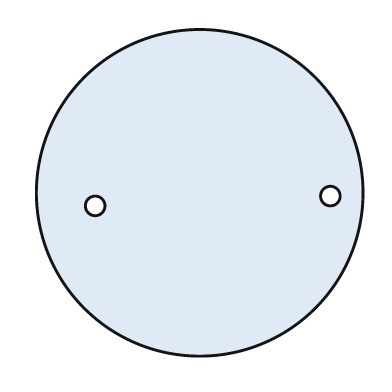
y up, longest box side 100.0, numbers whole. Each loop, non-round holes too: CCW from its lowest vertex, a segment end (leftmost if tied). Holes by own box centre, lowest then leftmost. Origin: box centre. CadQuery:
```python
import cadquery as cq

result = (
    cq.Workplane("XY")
    .moveTo(0.0, 0.0)
    .circle(50.0)
    .moveTo(-32.0, -4.0)
    .circle(3.0)
    .moveTo(40.0, -1.0)
    .circle(3.0)
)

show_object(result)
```